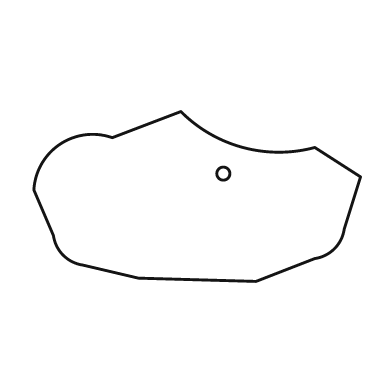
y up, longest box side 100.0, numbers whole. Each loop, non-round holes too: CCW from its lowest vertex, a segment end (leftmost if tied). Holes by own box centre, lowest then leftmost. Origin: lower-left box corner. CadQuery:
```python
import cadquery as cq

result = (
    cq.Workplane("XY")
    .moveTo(68.0, 0.0)
    .lineTo(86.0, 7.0)
    .threePointArc((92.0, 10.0), (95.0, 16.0))
    .lineTo(100.0, 32.0)
    .lineTo(86.0, 41.0)
    .threePointArc((64.0, 41.0), (45.0, 52.0))
    .lineTo(24.0, 44.0)
    .threePointArc((8.0, 42.0), (0.0, 28.0))
    .lineTo(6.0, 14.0)
    .threePointArc((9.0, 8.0), (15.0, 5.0))
    .lineTo(32.0, 1.0)
    .close()
    .moveTo(58.0, 33.0)
    .circle(2.0)
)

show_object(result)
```